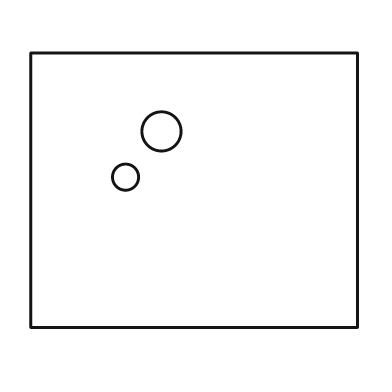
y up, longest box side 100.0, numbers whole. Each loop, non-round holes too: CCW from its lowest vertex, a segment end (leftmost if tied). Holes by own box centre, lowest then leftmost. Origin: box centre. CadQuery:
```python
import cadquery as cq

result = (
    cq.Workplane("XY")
    .moveTo(-50.0, -42.0)
    .lineTo(50.0, -42.0)
    .lineTo(50.0, 42.0)
    .lineTo(-50.0, 42.0)
    .close()
    .moveTo(-21.0, 4.0)
    .circle(4.0)
    .moveTo(-10.0, 18.0)
    .circle(6.0)
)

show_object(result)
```